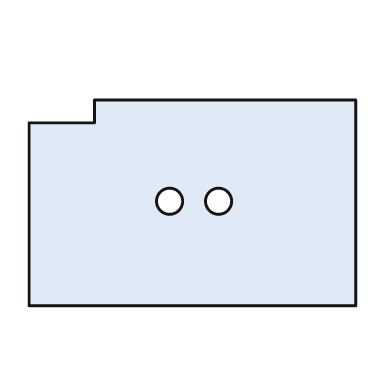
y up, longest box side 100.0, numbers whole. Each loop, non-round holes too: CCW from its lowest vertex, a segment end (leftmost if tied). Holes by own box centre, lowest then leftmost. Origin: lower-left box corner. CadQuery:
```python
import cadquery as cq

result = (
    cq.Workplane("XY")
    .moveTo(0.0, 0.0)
    .lineTo(100.0, 0.0)
    .lineTo(100.0, 63.0)
    .lineTo(20.0, 63.0)
    .lineTo(20.0, 56.0)
    .lineTo(0.0, 56.0)
    .close()
    .moveTo(43.0, 32.0)
    .circle(4.0)
    .moveTo(58.0, 32.0)
    .circle(4.0)
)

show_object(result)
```